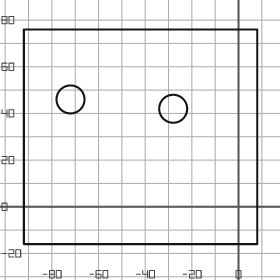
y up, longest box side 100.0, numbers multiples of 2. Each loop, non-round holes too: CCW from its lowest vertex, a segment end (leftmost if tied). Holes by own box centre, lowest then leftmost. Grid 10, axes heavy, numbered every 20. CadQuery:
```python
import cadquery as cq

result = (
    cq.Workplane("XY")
    .moveTo(-92.0, -16.0)
    .lineTo(8.0, -16.0)
    .lineTo(8.0, 76.0)
    .lineTo(-92.0, 76.0)
    .close()
    .moveTo(-28.0, 42.0)
    .circle(6.0)
    .moveTo(-72.0, 46.0)
    .circle(6.0)
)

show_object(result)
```